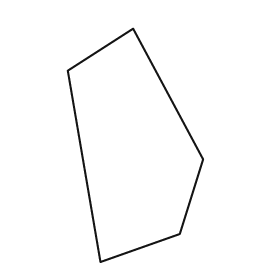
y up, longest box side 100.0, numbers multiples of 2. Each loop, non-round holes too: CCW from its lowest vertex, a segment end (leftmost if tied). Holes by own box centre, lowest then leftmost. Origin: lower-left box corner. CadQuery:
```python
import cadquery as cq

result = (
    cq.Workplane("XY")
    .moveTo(14.0, 0.0)
    .lineTo(48.0, 12.0)
    .lineTo(58.0, 44.0)
    .lineTo(28.0, 100.0)
    .lineTo(0.0, 82.0)
    .close()
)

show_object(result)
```